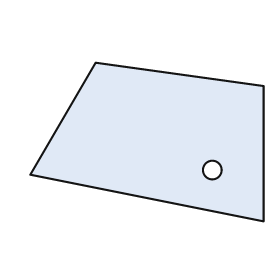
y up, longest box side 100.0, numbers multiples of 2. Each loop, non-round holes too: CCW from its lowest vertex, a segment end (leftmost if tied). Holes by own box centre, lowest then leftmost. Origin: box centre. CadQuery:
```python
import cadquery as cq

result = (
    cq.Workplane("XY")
    .moveTo(50.0, -34.0)
    .lineTo(50.0, 24.0)
    .lineTo(-22.0, 34.0)
    .lineTo(-50.0, -14.0)
    .close()
    .moveTo(28.0, -12.0)
    .circle(4.0)
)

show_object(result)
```